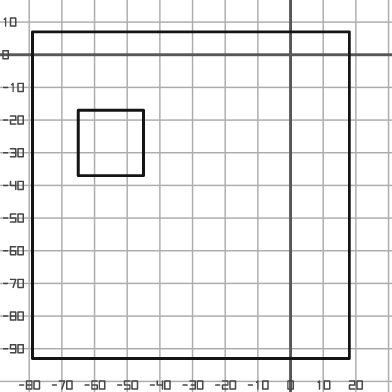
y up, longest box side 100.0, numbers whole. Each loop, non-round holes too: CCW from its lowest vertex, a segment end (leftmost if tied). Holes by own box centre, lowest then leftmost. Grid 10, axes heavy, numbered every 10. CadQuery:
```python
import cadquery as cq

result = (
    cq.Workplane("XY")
    .moveTo(-79.0, -93.0)
    .lineTo(18.0, -93.0)
    .lineTo(18.0, 7.0)
    .lineTo(-79.0, 7.0)
    .close()
    .moveTo(-65.0, -37.0)
    .lineTo(-45.0, -37.0)
    .lineTo(-45.0, -17.0)
    .lineTo(-65.0, -17.0)
    .close()
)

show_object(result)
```